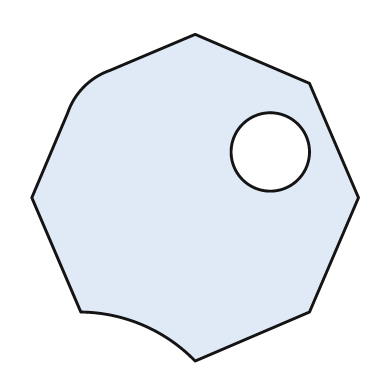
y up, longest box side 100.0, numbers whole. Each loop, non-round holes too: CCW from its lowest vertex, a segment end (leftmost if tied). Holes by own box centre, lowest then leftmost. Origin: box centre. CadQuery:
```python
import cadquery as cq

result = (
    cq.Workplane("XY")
    .moveTo(0.0, -50.0)
    .lineTo(35.0, -35.0)
    .lineTo(50.0, 0.0)
    .lineTo(35.0, 35.0)
    .lineTo(0.0, 50.0)
    .lineTo(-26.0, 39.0)
    .threePointArc((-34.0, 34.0), (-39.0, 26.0))
    .lineTo(-50.0, 0.0)
    .lineTo(-35.0, -35.0)
    .threePointArc((-16.0, -39.0), (0.0, -50.0))
    .close()
    .moveTo(23.0, 14.0)
    .circle(12.0)
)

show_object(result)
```